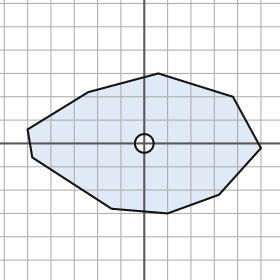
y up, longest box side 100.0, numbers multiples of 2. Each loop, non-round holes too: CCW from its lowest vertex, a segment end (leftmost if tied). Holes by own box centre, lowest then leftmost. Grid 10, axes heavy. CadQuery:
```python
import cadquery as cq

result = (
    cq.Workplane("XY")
    .moveTo(10.0, -30.0)
    .lineTo(32.0, -22.0)
    .lineTo(50.0, -2.0)
    .lineTo(38.0, 20.0)
    .lineTo(6.0, 30.0)
    .lineTo(-24.0, 22.0)
    .lineTo(-50.0, 6.0)
    .lineTo(-48.0, -6.0)
    .lineTo(-14.0, -28.0)
    .close()
    .moveTo(0.0, 0.0)
    .circle(4.0)
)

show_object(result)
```